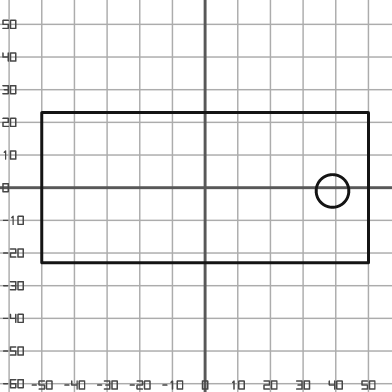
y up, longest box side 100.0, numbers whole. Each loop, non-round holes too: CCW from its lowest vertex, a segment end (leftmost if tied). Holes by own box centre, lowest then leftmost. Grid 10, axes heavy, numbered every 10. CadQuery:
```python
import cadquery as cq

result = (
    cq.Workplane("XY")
    .moveTo(-50.0, -23.0)
    .lineTo(50.0, -23.0)
    .lineTo(50.0, 23.0)
    .lineTo(-50.0, 23.0)
    .close()
    .moveTo(39.0, -1.0)
    .circle(5.0)
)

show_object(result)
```